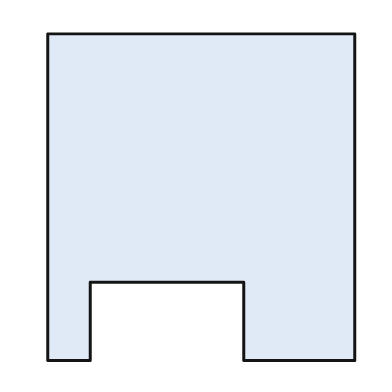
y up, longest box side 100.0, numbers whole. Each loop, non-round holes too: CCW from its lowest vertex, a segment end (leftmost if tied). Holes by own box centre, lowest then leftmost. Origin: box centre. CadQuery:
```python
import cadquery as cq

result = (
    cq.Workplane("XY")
    .moveTo(-47.0, -50.0)
    .lineTo(-34.0, -50.0)
    .lineTo(-34.0, -26.0)
    .lineTo(13.0, -26.0)
    .lineTo(13.0, -50.0)
    .lineTo(47.0, -50.0)
    .lineTo(47.0, 50.0)
    .lineTo(-47.0, 50.0)
    .close()
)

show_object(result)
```